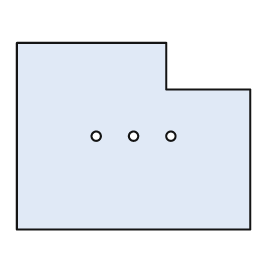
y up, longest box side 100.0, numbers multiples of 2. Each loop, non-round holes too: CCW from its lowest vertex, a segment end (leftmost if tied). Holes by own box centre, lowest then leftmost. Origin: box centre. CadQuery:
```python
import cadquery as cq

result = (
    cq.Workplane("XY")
    .moveTo(-50.0, -40.0)
    .lineTo(50.0, -40.0)
    .lineTo(50.0, 20.0)
    .lineTo(14.0, 20.0)
    .lineTo(14.0, 40.0)
    .lineTo(-50.0, 40.0)
    .close()
    .moveTo(-16.0, 0.0)
    .circle(2.0)
    .moveTo(0.0, 0.0)
    .circle(2.0)
    .moveTo(16.0, 0.0)
    .circle(2.0)
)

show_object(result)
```